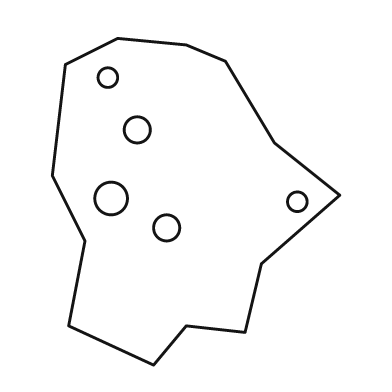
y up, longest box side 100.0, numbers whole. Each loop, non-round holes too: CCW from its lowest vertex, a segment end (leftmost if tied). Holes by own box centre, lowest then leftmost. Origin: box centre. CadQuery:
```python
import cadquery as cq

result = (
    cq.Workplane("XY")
    .moveTo(-13.0, -50.0)
    .lineTo(-3.0, -38.0)
    .lineTo(15.0, -40.0)
    .lineTo(20.0, -19.0)
    .lineTo(44.0, 2.0)
    .lineTo(24.0, 18.0)
    .lineTo(9.0, 43.0)
    .lineTo(-3.0, 48.0)
    .lineTo(-24.0, 50.0)
    .lineTo(-40.0, 42.0)
    .lineTo(-44.0, 8.0)
    .lineTo(-34.0, -12.0)
    .lineTo(-39.0, -38.0)
    .close()
    .moveTo(-9.0, -8.0)
    .circle(4.0)
    .moveTo(31.0, 0.0)
    .circle(3.0)
    .moveTo(-26.0, 1.0)
    .circle(5.0)
    .moveTo(-18.0, 22.0)
    .circle(4.0)
    .moveTo(-27.0, 38.0)
    .circle(3.0)
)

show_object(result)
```